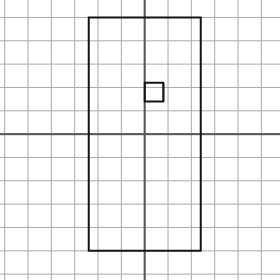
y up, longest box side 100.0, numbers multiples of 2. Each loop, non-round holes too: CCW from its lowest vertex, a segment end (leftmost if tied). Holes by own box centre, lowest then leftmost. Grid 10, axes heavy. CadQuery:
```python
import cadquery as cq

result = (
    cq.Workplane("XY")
    .moveTo(-24.0, -50.0)
    .lineTo(24.0, -50.0)
    .lineTo(24.0, 50.0)
    .lineTo(-24.0, 50.0)
    .close()
    .moveTo(0.0, 14.0)
    .lineTo(8.0, 14.0)
    .lineTo(8.0, 22.0)
    .lineTo(0.0, 22.0)
    .close()
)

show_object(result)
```